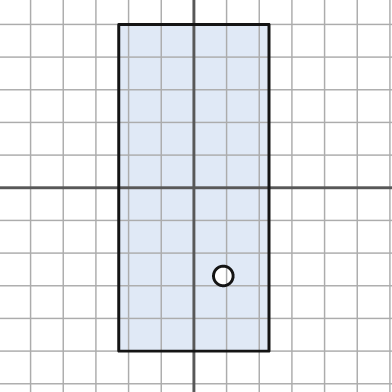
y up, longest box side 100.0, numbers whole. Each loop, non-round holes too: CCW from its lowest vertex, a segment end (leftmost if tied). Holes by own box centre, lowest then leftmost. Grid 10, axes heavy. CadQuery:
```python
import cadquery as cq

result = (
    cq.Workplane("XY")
    .moveTo(-23.0, -50.0)
    .lineTo(23.0, -50.0)
    .lineTo(23.0, 50.0)
    .lineTo(-23.0, 50.0)
    .close()
    .moveTo(9.0, -27.0)
    .circle(3.0)
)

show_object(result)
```